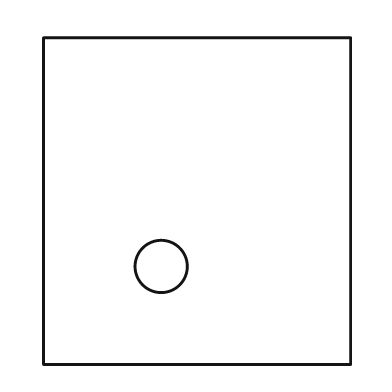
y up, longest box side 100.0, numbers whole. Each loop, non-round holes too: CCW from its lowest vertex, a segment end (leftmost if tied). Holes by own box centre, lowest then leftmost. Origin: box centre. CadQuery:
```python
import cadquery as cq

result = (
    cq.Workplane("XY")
    .moveTo(-47.0, -50.0)
    .lineTo(47.0, -50.0)
    .lineTo(47.0, 50.0)
    .lineTo(-47.0, 50.0)
    .close()
    .moveTo(-11.0, -20.0)
    .circle(8.0)
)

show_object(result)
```